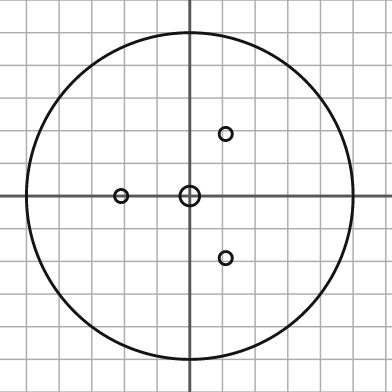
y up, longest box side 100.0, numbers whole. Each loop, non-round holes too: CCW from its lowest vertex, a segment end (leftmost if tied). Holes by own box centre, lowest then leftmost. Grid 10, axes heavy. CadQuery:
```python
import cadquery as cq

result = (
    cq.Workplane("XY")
    .moveTo(0.0, 0.0)
    .circle(50.0)
    .moveTo(11.0, -19.0)
    .circle(2.0)
    .moveTo(-21.0, 0.0)
    .circle(2.0)
    .moveTo(0.0, 0.0)
    .circle(3.0)
    .moveTo(11.0, 19.0)
    .circle(2.0)
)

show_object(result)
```